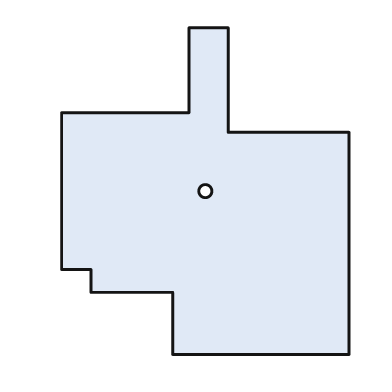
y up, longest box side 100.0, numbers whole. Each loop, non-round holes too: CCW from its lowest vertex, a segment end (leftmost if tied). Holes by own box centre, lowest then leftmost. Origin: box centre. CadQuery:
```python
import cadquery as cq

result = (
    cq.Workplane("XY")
    .moveTo(-10.0, -50.0)
    .lineTo(44.0, -50.0)
    .lineTo(44.0, 18.0)
    .lineTo(7.0, 18.0)
    .lineTo(7.0, 50.0)
    .lineTo(-5.0, 50.0)
    .lineTo(-5.0, 24.0)
    .lineTo(-44.0, 24.0)
    .lineTo(-44.0, -24.0)
    .lineTo(-35.0, -24.0)
    .lineTo(-35.0, -31.0)
    .lineTo(-10.0, -31.0)
    .close()
    .moveTo(0.0, 0.0)
    .circle(2.0)
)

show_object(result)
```